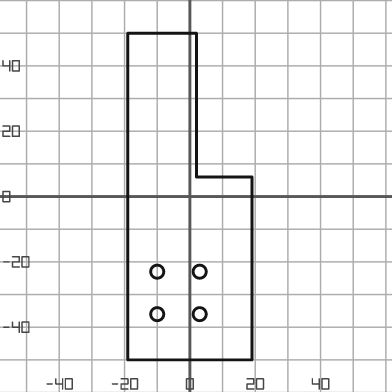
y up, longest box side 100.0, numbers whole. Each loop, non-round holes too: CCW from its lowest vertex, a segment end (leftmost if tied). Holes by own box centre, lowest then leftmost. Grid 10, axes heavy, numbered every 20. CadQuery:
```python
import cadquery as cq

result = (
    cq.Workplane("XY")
    .moveTo(-19.0, -50.0)
    .lineTo(19.0, -50.0)
    .lineTo(19.0, 6.0)
    .lineTo(2.0, 6.0)
    .lineTo(2.0, 50.0)
    .lineTo(-19.0, 50.0)
    .close()
    .moveTo(-10.0, -36.0)
    .circle(2.0)
    .moveTo(3.0, -36.0)
    .circle(2.0)
    .moveTo(-10.0, -23.0)
    .circle(2.0)
    .moveTo(3.0, -23.0)
    .circle(2.0)
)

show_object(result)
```